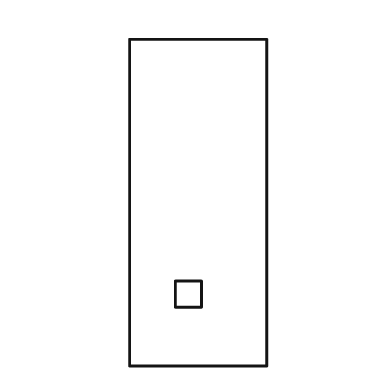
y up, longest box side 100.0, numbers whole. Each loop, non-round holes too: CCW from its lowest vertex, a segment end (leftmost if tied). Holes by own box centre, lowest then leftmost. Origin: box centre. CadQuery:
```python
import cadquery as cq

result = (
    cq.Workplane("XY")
    .moveTo(-21.0, -50.0)
    .lineTo(21.0, -50.0)
    .lineTo(21.0, 50.0)
    .lineTo(-21.0, 50.0)
    .close()
    .moveTo(-7.0, -32.0)
    .lineTo(1.0, -32.0)
    .lineTo(1.0, -24.0)
    .lineTo(-7.0, -24.0)
    .close()
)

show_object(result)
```